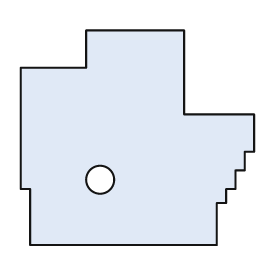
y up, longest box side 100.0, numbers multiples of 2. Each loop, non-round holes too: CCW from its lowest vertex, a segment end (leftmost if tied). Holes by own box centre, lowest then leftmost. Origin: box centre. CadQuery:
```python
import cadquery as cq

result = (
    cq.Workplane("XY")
    .moveTo(-46.0, -46.0)
    .lineTo(34.0, -46.0)
    .lineTo(34.0, -28.0)
    .lineTo(38.0, -28.0)
    .lineTo(38.0, -22.0)
    .lineTo(42.0, -22.0)
    .lineTo(42.0, -14.0)
    .lineTo(46.0, -14.0)
    .lineTo(46.0, -6.0)
    .lineTo(50.0, -6.0)
    .lineTo(50.0, 10.0)
    .lineTo(20.0, 10.0)
    .lineTo(20.0, 46.0)
    .lineTo(-22.0, 46.0)
    .lineTo(-22.0, 30.0)
    .lineTo(-50.0, 30.0)
    .lineTo(-50.0, -22.0)
    .lineTo(-46.0, -22.0)
    .close()
    .moveTo(-16.0, -18.0)
    .circle(6.0)
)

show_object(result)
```